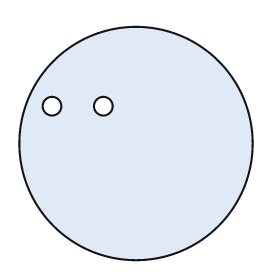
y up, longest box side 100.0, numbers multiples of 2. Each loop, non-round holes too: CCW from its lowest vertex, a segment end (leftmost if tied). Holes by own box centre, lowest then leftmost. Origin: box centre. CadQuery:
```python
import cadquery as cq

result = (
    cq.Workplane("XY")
    .moveTo(0.0, 0.0)
    .circle(50.0)
    .moveTo(-36.0, 16.0)
    .circle(4.0)
    .moveTo(-14.0, 16.0)
    .circle(4.0)
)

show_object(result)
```